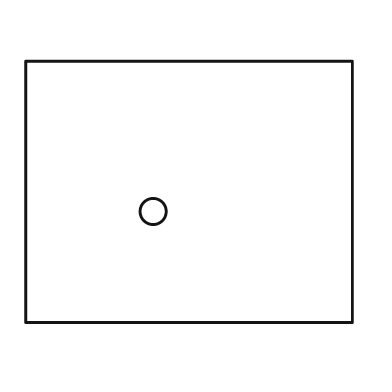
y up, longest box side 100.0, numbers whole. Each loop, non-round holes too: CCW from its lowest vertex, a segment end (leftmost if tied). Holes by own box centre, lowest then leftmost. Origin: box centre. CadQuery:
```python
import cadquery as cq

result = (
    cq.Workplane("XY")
    .moveTo(-50.0, -40.0)
    .lineTo(50.0, -40.0)
    .lineTo(50.0, 40.0)
    .lineTo(-50.0, 40.0)
    .close()
    .moveTo(-11.0, -6.0)
    .circle(4.0)
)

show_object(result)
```